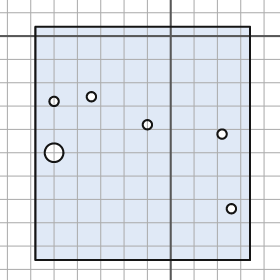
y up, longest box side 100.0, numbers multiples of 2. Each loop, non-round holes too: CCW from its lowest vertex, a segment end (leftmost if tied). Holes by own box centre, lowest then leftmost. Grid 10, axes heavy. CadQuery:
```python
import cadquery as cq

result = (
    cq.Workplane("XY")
    .moveTo(-58.0, -96.0)
    .lineTo(34.0, -96.0)
    .lineTo(34.0, 4.0)
    .lineTo(-58.0, 4.0)
    .close()
    .moveTo(26.0, -74.0)
    .circle(2.0)
    .moveTo(-50.0, -50.0)
    .circle(4.0)
    .moveTo(22.0, -42.0)
    .circle(2.0)
    .moveTo(-10.0, -38.0)
    .circle(2.0)
    .moveTo(-50.0, -28.0)
    .circle(2.0)
    .moveTo(-34.0, -26.0)
    .circle(2.0)
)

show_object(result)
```